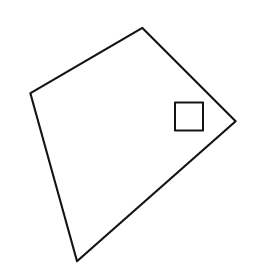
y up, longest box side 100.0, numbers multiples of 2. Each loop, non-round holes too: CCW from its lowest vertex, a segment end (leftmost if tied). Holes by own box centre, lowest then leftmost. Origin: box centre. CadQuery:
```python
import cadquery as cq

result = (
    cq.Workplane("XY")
    .moveTo(-24.0, -50.0)
    .lineTo(44.0, 10.0)
    .lineTo(4.0, 50.0)
    .lineTo(-44.0, 22.0)
    .close()
    .moveTo(18.0, 6.0)
    .lineTo(30.0, 6.0)
    .lineTo(30.0, 18.0)
    .lineTo(18.0, 18.0)
    .close()
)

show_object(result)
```